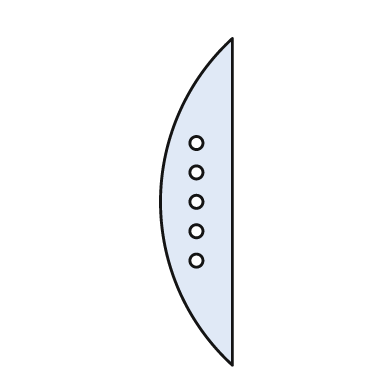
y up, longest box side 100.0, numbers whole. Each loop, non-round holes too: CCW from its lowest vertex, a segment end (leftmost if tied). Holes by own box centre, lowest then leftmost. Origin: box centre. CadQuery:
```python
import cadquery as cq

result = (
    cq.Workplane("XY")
    .moveTo(11.0, -50.0)
    .lineTo(11.0, 50.0)
    .threePointArc((-11.0, 0.0), (11.0, -50.0))
    .close()
    .moveTo(0.0, -18.0)
    .circle(2.0)
    .moveTo(0.0, -9.0)
    .circle(2.0)
    .moveTo(0.0, 0.0)
    .circle(2.0)
    .moveTo(0.0, 9.0)
    .circle(2.0)
    .moveTo(0.0, 18.0)
    .circle(2.0)
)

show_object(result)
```